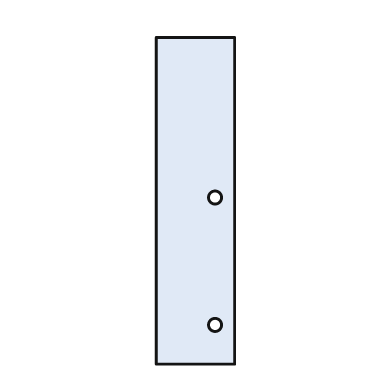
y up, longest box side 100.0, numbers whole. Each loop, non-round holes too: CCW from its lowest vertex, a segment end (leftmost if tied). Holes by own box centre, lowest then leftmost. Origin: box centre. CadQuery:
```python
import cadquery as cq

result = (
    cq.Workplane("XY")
    .moveTo(-12.0, -50.0)
    .lineTo(12.0, -50.0)
    .lineTo(12.0, 50.0)
    .lineTo(-12.0, 50.0)
    .close()
    .moveTo(6.0, -38.0)
    .circle(2.0)
    .moveTo(6.0, 1.0)
    .circle(2.0)
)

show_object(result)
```